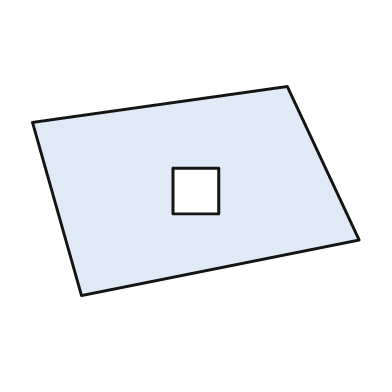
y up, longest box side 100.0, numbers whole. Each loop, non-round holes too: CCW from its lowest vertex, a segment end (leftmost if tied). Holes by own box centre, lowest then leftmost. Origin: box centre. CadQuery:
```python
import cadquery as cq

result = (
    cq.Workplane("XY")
    .moveTo(-35.0, -32.0)
    .lineTo(50.0, -15.0)
    .lineTo(28.0, 32.0)
    .lineTo(-50.0, 21.0)
    .close()
    .moveTo(-7.0, -7.0)
    .lineTo(7.0, -7.0)
    .lineTo(7.0, 7.0)
    .lineTo(-7.0, 7.0)
    .close()
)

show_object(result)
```